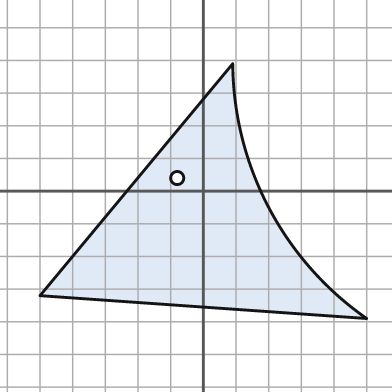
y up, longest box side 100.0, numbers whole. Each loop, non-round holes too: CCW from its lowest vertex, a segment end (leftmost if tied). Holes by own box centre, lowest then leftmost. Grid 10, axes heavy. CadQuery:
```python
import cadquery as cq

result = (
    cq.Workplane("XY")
    .moveTo(50.0, -39.0)
    .threePointArc((20.0, -5.0), (9.0, 39.0))
    .lineTo(-50.0, -32.0)
    .close()
    .moveTo(-8.0, 4.0)
    .circle(2.0)
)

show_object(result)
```